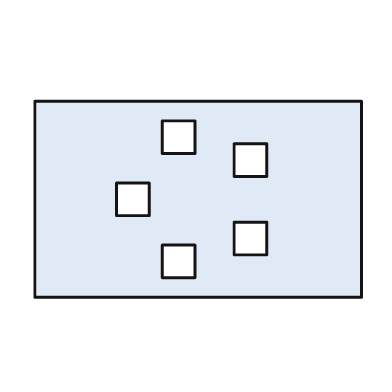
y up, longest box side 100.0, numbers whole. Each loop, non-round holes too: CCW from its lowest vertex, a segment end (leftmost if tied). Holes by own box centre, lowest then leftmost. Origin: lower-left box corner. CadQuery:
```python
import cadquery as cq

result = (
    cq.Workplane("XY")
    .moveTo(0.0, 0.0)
    .lineTo(100.0, 0.0)
    .lineTo(100.0, 60.0)
    .lineTo(0.0, 60.0)
    .close()
    .moveTo(39.0, 6.0)
    .lineTo(49.0, 6.0)
    .lineTo(49.0, 16.0)
    .lineTo(39.0, 16.0)
    .close()
    .moveTo(61.0, 13.0)
    .lineTo(71.0, 13.0)
    .lineTo(71.0, 23.0)
    .lineTo(61.0, 23.0)
    .close()
    .moveTo(25.0, 25.0)
    .lineTo(35.0, 25.0)
    .lineTo(35.0, 35.0)
    .lineTo(25.0, 35.0)
    .close()
    .moveTo(61.0, 37.0)
    .lineTo(71.0, 37.0)
    .lineTo(71.0, 47.0)
    .lineTo(61.0, 47.0)
    .close()
    .moveTo(39.0, 44.0)
    .lineTo(49.0, 44.0)
    .lineTo(49.0, 54.0)
    .lineTo(39.0, 54.0)
    .close()
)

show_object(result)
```